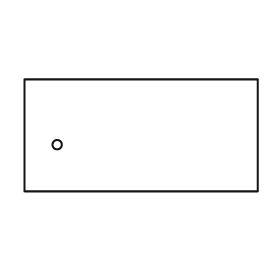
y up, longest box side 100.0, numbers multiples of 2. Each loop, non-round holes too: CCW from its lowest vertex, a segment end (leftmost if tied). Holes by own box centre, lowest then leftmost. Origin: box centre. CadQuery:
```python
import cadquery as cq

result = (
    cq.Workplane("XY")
    .moveTo(-50.0, -24.0)
    .lineTo(50.0, -24.0)
    .lineTo(50.0, 24.0)
    .lineTo(-50.0, 24.0)
    .close()
    .moveTo(-36.0, -4.0)
    .circle(2.0)
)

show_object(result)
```